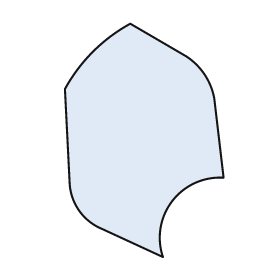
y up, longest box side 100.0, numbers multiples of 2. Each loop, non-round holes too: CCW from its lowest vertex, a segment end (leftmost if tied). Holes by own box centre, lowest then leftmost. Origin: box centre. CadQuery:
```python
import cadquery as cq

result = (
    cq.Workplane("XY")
    .moveTo(8.0, -50.0)
    .threePointArc((12.0, -26.0), (34.0, -16.0))
    .lineTo(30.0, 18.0)
    .threePointArc((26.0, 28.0), (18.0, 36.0))
    .lineTo(-6.0, 50.0)
    .threePointArc((-22.0, 38.0), (-34.0, 22.0))
    .lineTo(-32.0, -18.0)
    .threePointArc((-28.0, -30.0), (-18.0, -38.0))
    .close()
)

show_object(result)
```